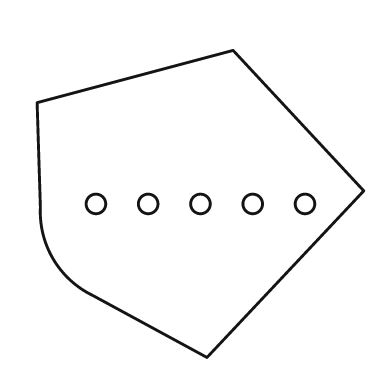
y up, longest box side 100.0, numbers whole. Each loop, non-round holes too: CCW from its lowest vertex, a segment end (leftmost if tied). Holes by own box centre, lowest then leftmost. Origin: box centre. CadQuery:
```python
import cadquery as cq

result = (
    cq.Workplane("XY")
    .moveTo(2.0, -47.0)
    .lineTo(50.0, 4.0)
    .lineTo(10.0, 47.0)
    .lineTo(-50.0, 31.0)
    .lineTo(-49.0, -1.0)
    .threePointArc((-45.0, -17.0), (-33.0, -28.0))
    .close()
    .moveTo(-32.0, 0.0)
    .circle(3.0)
    .moveTo(-16.0, 0.0)
    .circle(3.0)
    .moveTo(0.0, 0.0)
    .circle(3.0)
    .moveTo(16.0, 0.0)
    .circle(3.0)
    .moveTo(32.0, 0.0)
    .circle(3.0)
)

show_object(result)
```